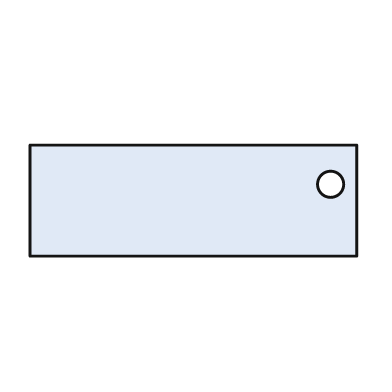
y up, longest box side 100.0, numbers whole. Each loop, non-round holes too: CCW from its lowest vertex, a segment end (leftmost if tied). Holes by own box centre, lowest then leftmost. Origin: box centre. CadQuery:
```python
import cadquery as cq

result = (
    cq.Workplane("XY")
    .moveTo(-50.0, -17.0)
    .lineTo(50.0, -17.0)
    .lineTo(50.0, 17.0)
    .lineTo(-50.0, 17.0)
    .close()
    .moveTo(42.0, 5.0)
    .circle(4.0)
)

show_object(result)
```